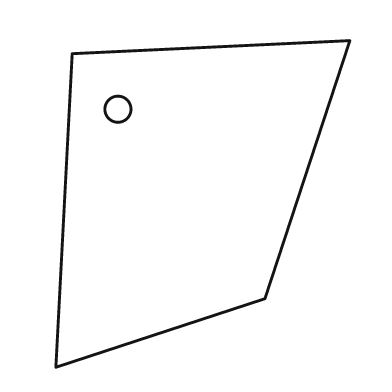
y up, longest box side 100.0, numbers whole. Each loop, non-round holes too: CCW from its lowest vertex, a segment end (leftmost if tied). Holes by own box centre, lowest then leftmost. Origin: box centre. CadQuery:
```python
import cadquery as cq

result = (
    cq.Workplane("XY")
    .moveTo(-45.0, -50.0)
    .lineTo(19.0, -29.0)
    .lineTo(45.0, 50.0)
    .lineTo(-40.0, 46.0)
    .close()
    .moveTo(-26.0, 29.0)
    .circle(4.0)
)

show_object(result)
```